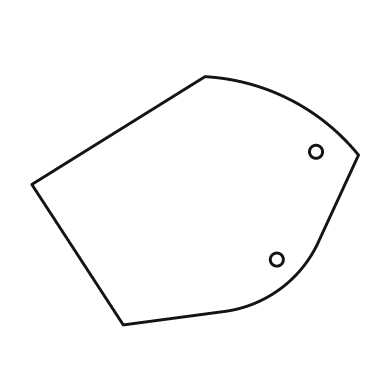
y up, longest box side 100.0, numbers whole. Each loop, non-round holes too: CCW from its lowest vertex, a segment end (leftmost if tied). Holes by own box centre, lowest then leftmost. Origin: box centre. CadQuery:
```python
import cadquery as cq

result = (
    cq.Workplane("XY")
    .moveTo(-22.0, -38.0)
    .lineTo(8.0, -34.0)
    .threePointArc((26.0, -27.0), (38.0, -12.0))
    .lineTo(50.0, 14.0)
    .threePointArc((29.0, 31.0), (3.0, 38.0))
    .lineTo(-50.0, 5.0)
    .close()
    .moveTo(25.0, -18.0)
    .circle(2.0)
    .moveTo(37.0, 15.0)
    .circle(2.0)
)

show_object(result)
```